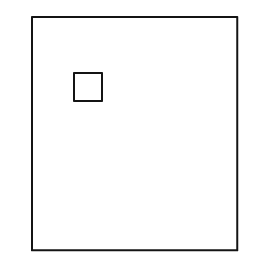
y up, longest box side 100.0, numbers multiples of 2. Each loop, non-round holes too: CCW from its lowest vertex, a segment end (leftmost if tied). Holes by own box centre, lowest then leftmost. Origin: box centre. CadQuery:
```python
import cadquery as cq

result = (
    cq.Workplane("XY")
    .moveTo(-44.0, -50.0)
    .lineTo(44.0, -50.0)
    .lineTo(44.0, 50.0)
    .lineTo(-44.0, 50.0)
    .close()
    .moveTo(-26.0, 14.0)
    .lineTo(-14.0, 14.0)
    .lineTo(-14.0, 26.0)
    .lineTo(-26.0, 26.0)
    .close()
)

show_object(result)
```